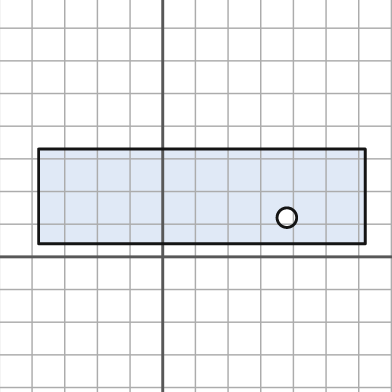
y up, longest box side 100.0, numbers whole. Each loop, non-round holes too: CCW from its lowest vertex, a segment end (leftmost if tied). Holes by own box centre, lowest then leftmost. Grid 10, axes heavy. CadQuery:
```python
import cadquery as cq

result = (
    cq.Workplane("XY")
    .moveTo(-38.0, 4.0)
    .lineTo(62.0, 4.0)
    .lineTo(62.0, 33.0)
    .lineTo(-38.0, 33.0)
    .close()
    .moveTo(38.0, 12.0)
    .circle(3.0)
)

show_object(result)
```